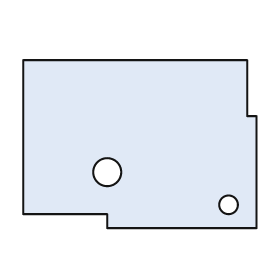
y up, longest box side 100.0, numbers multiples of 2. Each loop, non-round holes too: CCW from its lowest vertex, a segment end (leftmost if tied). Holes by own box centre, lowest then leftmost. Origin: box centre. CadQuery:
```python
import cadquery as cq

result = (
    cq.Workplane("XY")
    .moveTo(-14.0, -36.0)
    .lineTo(50.0, -36.0)
    .lineTo(50.0, 12.0)
    .lineTo(46.0, 12.0)
    .lineTo(46.0, 36.0)
    .lineTo(-50.0, 36.0)
    .lineTo(-50.0, -30.0)
    .lineTo(-14.0, -30.0)
    .close()
    .moveTo(38.0, -26.0)
    .circle(4.0)
    .moveTo(-14.0, -12.0)
    .circle(6.0)
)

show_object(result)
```